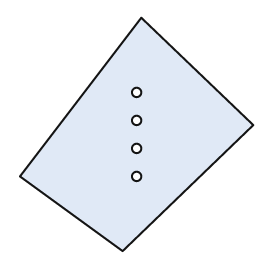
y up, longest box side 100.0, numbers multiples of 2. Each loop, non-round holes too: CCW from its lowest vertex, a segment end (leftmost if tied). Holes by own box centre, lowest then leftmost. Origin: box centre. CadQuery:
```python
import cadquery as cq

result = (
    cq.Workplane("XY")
    .moveTo(-6.0, -50.0)
    .lineTo(50.0, 4.0)
    .lineTo(2.0, 50.0)
    .lineTo(-50.0, -18.0)
    .close()
    .moveTo(0.0, -18.0)
    .circle(2.0)
    .moveTo(0.0, -6.0)
    .circle(2.0)
    .moveTo(0.0, 6.0)
    .circle(2.0)
    .moveTo(0.0, 18.0)
    .circle(2.0)
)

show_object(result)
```